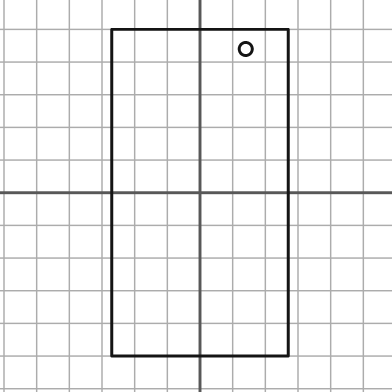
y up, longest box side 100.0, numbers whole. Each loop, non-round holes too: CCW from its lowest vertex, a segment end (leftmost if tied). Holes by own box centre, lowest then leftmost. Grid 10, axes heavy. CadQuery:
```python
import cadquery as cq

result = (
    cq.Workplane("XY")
    .moveTo(-27.0, -50.0)
    .lineTo(27.0, -50.0)
    .lineTo(27.0, 50.0)
    .lineTo(-27.0, 50.0)
    .close()
    .moveTo(14.0, 44.0)
    .circle(2.0)
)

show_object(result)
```